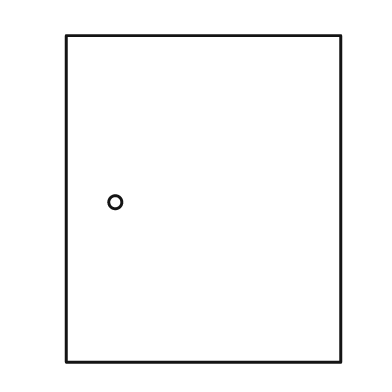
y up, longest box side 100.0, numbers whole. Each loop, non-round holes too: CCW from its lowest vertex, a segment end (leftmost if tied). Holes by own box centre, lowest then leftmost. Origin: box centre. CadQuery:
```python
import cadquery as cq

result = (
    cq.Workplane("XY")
    .moveTo(-42.0, -50.0)
    .lineTo(42.0, -50.0)
    .lineTo(42.0, 50.0)
    .lineTo(-42.0, 50.0)
    .close()
    .moveTo(-27.0, -1.0)
    .circle(2.0)
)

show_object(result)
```